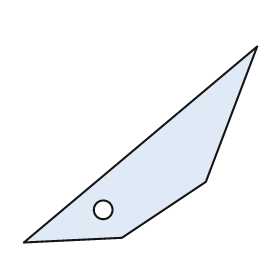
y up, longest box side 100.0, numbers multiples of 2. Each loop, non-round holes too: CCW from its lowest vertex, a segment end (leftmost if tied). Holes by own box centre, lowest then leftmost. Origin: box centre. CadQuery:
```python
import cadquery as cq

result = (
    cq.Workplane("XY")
    .moveTo(-50.0, -42.0)
    .lineTo(-8.0, -40.0)
    .lineTo(28.0, -16.0)
    .lineTo(50.0, 42.0)
    .close()
    .moveTo(-16.0, -28.0)
    .circle(4.0)
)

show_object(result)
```